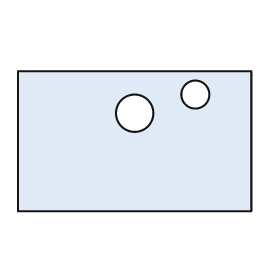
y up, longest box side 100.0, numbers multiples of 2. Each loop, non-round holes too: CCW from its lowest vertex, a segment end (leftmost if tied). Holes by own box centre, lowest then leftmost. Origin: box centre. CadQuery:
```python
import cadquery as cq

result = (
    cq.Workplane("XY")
    .moveTo(-50.0, -30.0)
    .lineTo(50.0, -30.0)
    .lineTo(50.0, 30.0)
    .lineTo(-50.0, 30.0)
    .close()
    .moveTo(0.0, 12.0)
    .circle(8.0)
    .moveTo(26.0, 20.0)
    .circle(6.0)
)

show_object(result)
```